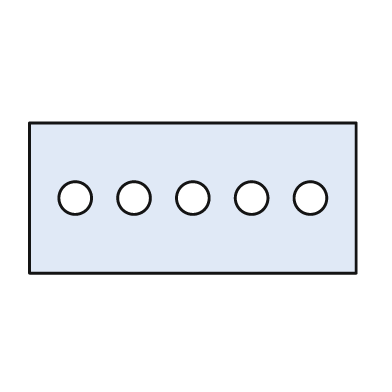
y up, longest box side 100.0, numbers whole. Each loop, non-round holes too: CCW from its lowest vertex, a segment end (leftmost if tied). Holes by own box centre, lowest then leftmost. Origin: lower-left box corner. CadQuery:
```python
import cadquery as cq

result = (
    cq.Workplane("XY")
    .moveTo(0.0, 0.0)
    .lineTo(100.0, 0.0)
    .lineTo(100.0, 46.0)
    .lineTo(0.0, 46.0)
    .close()
    .moveTo(14.0, 23.0)
    .circle(5.0)
    .moveTo(32.0, 23.0)
    .circle(5.0)
    .moveTo(50.0, 23.0)
    .circle(5.0)
    .moveTo(68.0, 23.0)
    .circle(5.0)
    .moveTo(86.0, 23.0)
    .circle(5.0)
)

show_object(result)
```